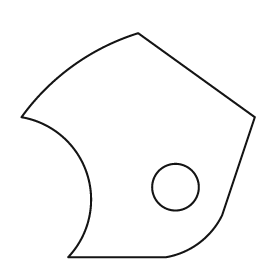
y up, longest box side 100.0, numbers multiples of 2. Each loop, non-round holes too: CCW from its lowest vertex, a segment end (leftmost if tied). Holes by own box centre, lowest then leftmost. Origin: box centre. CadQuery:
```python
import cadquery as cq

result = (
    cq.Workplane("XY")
    .moveTo(-30.0, -48.0)
    .lineTo(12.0, -48.0)
    .threePointArc((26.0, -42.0), (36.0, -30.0))
    .lineTo(50.0, 12.0)
    .lineTo(0.0, 48.0)
    .threePointArc((-28.0, 34.0), (-50.0, 12.0))
    .threePointArc((-22.0, -12.0), (-30.0, -48.0))
    .close()
    .moveTo(16.0, -18.0)
    .circle(10.0)
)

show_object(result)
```